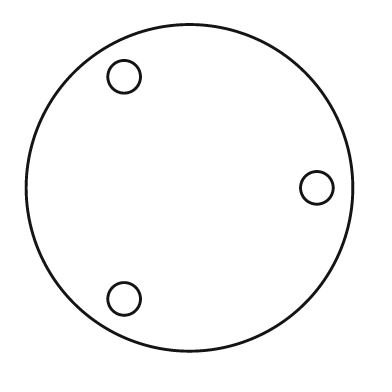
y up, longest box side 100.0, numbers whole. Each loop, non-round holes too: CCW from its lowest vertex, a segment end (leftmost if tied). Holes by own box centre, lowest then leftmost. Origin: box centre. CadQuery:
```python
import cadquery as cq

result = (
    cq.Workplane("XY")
    .moveTo(0.0, 0.0)
    .circle(50.0)
    .moveTo(-20.0, -34.0)
    .circle(5.0)
    .moveTo(39.0, 0.0)
    .circle(5.0)
    .moveTo(-20.0, 34.0)
    .circle(5.0)
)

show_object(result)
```